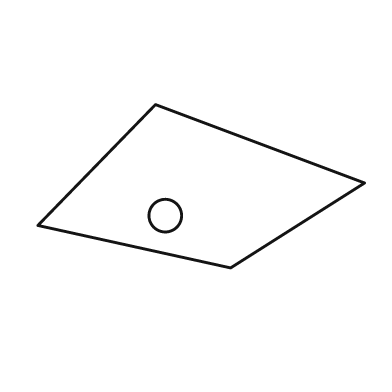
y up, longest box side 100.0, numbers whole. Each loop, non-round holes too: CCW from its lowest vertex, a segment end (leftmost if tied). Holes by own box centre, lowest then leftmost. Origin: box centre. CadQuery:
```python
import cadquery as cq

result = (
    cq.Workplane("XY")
    .moveTo(9.0, -25.0)
    .lineTo(50.0, 1.0)
    .lineTo(-14.0, 25.0)
    .lineTo(-50.0, -12.0)
    .close()
    .moveTo(-11.0, -9.0)
    .circle(5.0)
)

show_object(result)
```